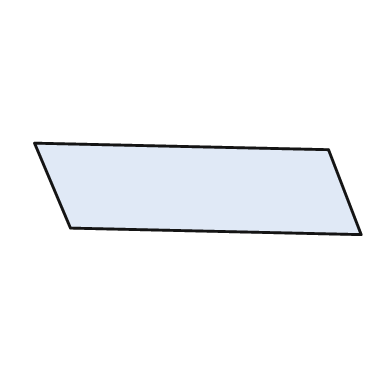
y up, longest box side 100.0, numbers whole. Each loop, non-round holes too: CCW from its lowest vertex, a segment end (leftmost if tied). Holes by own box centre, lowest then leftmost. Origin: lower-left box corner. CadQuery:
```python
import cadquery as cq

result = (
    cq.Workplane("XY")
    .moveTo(100.0, 0.0)
    .lineTo(90.0, 26.0)
    .lineTo(0.0, 28.0)
    .lineTo(11.0, 2.0)
    .close()
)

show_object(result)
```